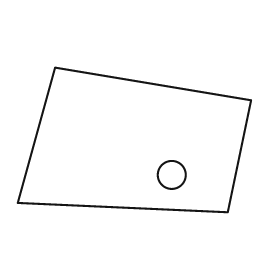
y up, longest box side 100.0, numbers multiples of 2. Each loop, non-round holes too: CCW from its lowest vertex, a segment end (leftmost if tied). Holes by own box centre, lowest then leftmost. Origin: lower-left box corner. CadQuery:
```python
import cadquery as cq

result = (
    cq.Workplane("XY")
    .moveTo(90.0, 0.0)
    .lineTo(100.0, 48.0)
    .lineTo(16.0, 62.0)
    .lineTo(0.0, 4.0)
    .close()
    .moveTo(66.0, 16.0)
    .circle(6.0)
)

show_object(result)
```